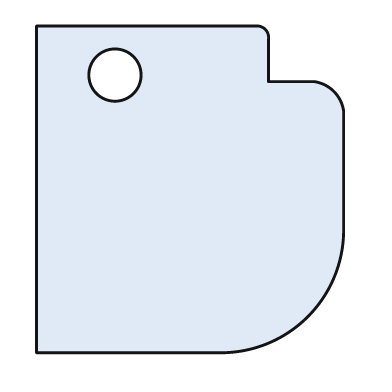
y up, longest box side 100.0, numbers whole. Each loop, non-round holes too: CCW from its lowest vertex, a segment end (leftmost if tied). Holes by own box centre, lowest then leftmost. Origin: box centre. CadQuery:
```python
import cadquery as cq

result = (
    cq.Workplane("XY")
    .moveTo(-47.0, -50.0)
    .lineTo(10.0, -50.0)
    .threePointArc((36.0, -39.0), (47.0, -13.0))
    .lineTo(47.0, 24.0)
    .threePointArc((44.0, 30.0), (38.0, 33.0))
    .lineTo(24.0, 33.0)
    .lineTo(24.0, 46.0)
    .threePointArc((23.0, 49.0), (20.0, 50.0))
    .lineTo(-47.0, 50.0)
    .close()
    .moveTo(-23.0, 35.0)
    .circle(8.0)
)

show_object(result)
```